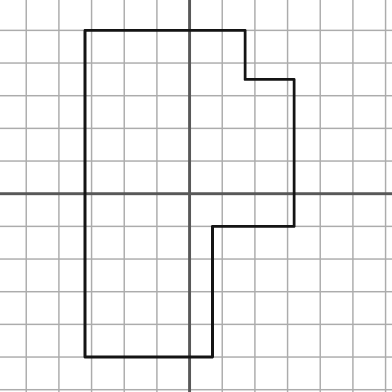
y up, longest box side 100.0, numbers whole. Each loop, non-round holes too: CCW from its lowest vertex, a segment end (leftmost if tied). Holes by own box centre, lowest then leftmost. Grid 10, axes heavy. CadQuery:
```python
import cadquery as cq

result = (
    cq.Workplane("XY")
    .moveTo(-32.0, -50.0)
    .lineTo(7.0, -50.0)
    .lineTo(7.0, -10.0)
    .lineTo(32.0, -10.0)
    .lineTo(32.0, 35.0)
    .lineTo(17.0, 35.0)
    .lineTo(17.0, 50.0)
    .lineTo(-32.0, 50.0)
    .close()
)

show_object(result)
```